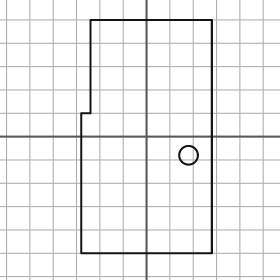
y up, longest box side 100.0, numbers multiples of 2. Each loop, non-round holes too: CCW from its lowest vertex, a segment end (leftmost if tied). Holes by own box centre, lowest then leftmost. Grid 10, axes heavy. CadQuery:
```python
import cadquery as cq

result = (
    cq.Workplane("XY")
    .moveTo(-28.0, -50.0)
    .lineTo(28.0, -50.0)
    .lineTo(28.0, 50.0)
    .lineTo(-24.0, 50.0)
    .lineTo(-24.0, 10.0)
    .lineTo(-28.0, 10.0)
    .close()
    .moveTo(18.0, -8.0)
    .circle(4.0)
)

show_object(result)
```